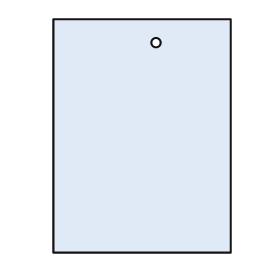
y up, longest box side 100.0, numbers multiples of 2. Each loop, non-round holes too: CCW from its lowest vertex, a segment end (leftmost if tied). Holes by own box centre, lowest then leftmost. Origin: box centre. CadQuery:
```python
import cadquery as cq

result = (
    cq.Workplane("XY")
    .moveTo(-38.0, -50.0)
    .lineTo(38.0, -50.0)
    .lineTo(38.0, 50.0)
    .lineTo(-38.0, 50.0)
    .close()
    .moveTo(6.0, 40.0)
    .circle(2.0)
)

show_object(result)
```